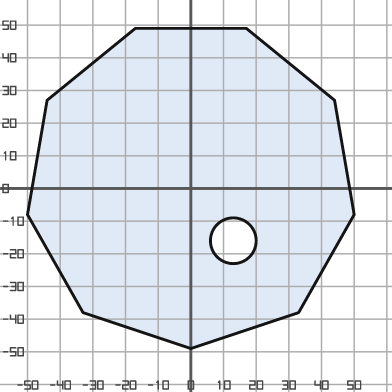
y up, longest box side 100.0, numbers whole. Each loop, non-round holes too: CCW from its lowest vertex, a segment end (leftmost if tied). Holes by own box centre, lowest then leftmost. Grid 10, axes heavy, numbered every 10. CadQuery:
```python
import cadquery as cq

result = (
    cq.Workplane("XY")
    .moveTo(0.0, -49.0)
    .lineTo(33.0, -38.0)
    .lineTo(50.0, -8.0)
    .lineTo(44.0, 27.0)
    .lineTo(17.0, 49.0)
    .lineTo(-17.0, 49.0)
    .lineTo(-44.0, 27.0)
    .lineTo(-50.0, -8.0)
    .lineTo(-33.0, -38.0)
    .close()
    .moveTo(13.0, -16.0)
    .circle(7.0)
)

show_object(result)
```